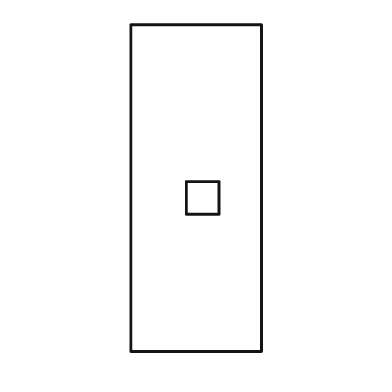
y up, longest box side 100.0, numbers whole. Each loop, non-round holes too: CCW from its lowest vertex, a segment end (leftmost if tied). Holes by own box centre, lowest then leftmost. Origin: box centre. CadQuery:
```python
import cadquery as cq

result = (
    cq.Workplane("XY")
    .moveTo(-20.0, -50.0)
    .lineTo(20.0, -50.0)
    .lineTo(20.0, 50.0)
    .lineTo(-20.0, 50.0)
    .close()
    .moveTo(-3.0, -8.0)
    .lineTo(7.0, -8.0)
    .lineTo(7.0, 2.0)
    .lineTo(-3.0, 2.0)
    .close()
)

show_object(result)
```